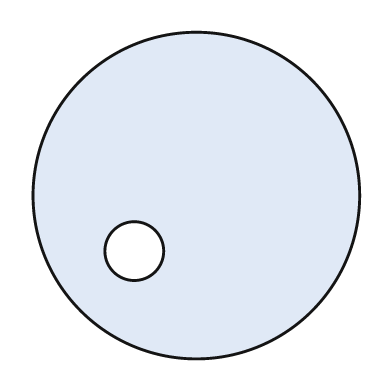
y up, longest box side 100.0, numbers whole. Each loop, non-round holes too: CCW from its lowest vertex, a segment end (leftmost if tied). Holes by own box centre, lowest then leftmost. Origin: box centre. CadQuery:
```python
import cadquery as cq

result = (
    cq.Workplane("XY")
    .moveTo(0.0, 0.0)
    .circle(50.0)
    .moveTo(-19.0, -17.0)
    .circle(9.0)
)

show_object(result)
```